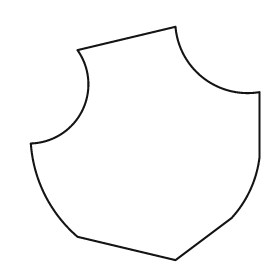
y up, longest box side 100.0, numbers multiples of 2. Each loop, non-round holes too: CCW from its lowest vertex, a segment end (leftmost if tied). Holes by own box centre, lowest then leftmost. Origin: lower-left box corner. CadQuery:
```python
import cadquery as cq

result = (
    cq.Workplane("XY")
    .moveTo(62.0, 0.0)
    .lineTo(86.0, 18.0)
    .threePointArc((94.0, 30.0), (98.0, 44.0))
    .lineTo(98.0, 72.0)
    .threePointArc((74.0, 78.0), (62.0, 100.0))
    .lineTo(20.0, 90.0)
    .threePointArc((22.0, 64.0), (0.0, 50.0))
    .threePointArc((6.0, 28.0), (20.0, 10.0))
    .close()
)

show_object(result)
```